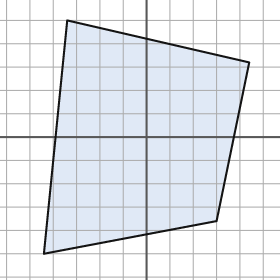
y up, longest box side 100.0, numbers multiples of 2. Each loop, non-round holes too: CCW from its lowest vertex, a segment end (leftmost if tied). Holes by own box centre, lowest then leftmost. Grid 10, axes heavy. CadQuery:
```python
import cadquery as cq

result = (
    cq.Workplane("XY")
    .moveTo(-44.0, -50.0)
    .lineTo(30.0, -36.0)
    .lineTo(44.0, 32.0)
    .lineTo(-34.0, 50.0)
    .close()
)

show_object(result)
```